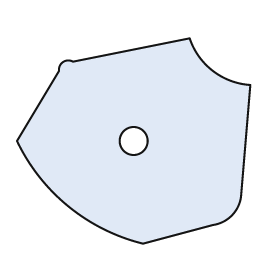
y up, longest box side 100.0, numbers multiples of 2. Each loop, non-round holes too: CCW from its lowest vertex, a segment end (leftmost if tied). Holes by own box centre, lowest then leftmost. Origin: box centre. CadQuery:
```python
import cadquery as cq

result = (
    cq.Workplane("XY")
    .moveTo(4.0, -44.0)
    .lineTo(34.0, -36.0)
    .threePointArc((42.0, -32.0), (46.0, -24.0))
    .lineTo(50.0, 24.0)
    .threePointArc((34.0, 30.0), (24.0, 44.0))
    .lineTo(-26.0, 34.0)
    .threePointArc((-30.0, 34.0), (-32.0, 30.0))
    .lineTo(-50.0, 0.0)
    .threePointArc((-28.0, -28.0), (4.0, -44.0))
    .close()
    .moveTo(0.0, 0.0)
    .circle(6.0)
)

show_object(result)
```